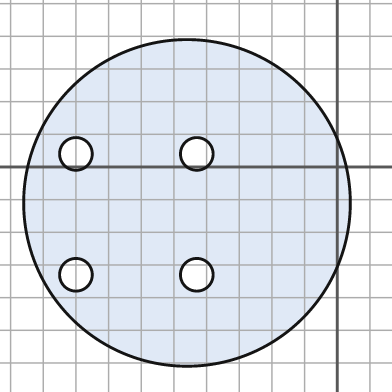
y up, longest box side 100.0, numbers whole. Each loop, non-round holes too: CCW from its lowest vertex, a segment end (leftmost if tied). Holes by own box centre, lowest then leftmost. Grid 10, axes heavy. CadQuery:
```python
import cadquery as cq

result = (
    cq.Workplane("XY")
    .moveTo(-46.0, -11.0)
    .circle(50.0)
    .moveTo(-80.0, -33.0)
    .circle(5.0)
    .moveTo(-43.0, -33.0)
    .circle(5.0)
    .moveTo(-80.0, 4.0)
    .circle(5.0)
    .moveTo(-43.0, 4.0)
    .circle(5.0)
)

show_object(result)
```